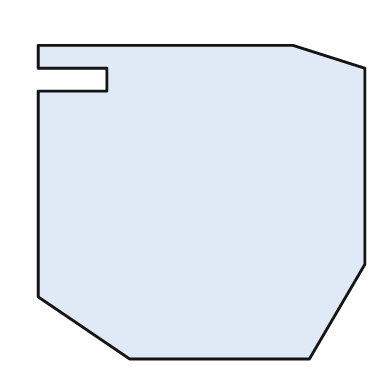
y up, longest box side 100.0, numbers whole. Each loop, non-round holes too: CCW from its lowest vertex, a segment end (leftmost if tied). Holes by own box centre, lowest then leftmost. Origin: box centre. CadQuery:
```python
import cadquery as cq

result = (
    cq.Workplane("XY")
    .moveTo(-22.0, -48.0)
    .lineTo(33.0, -48.0)
    .lineTo(50.0, -19.0)
    .lineTo(50.0, 41.0)
    .lineTo(28.0, 48.0)
    .lineTo(-50.0, 48.0)
    .lineTo(-50.0, 41.0)
    .lineTo(-29.0, 41.0)
    .lineTo(-29.0, 34.0)
    .lineTo(-50.0, 34.0)
    .lineTo(-50.0, -29.0)
    .close()
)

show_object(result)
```